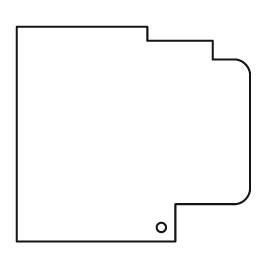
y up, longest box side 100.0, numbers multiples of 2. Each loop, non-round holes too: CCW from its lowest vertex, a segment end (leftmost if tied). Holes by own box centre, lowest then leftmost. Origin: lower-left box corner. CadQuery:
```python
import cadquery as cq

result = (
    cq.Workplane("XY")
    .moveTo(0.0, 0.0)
    .lineTo(68.0, 0.0)
    .lineTo(68.0, 16.0)
    .lineTo(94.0, 16.0)
    .threePointArc((98.0, 18.0), (100.0, 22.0))
    .lineTo(100.0, 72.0)
    .threePointArc((98.0, 76.0), (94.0, 78.0))
    .lineTo(84.0, 78.0)
    .lineTo(84.0, 86.0)
    .lineTo(56.0, 86.0)
    .lineTo(56.0, 92.0)
    .lineTo(0.0, 92.0)
    .close()
    .moveTo(62.0, 6.0)
    .circle(2.0)
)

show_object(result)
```